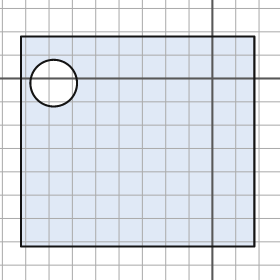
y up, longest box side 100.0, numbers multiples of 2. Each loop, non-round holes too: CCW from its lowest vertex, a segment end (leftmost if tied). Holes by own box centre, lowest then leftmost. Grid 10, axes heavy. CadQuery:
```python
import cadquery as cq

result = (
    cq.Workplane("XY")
    .moveTo(-82.0, -72.0)
    .lineTo(18.0, -72.0)
    .lineTo(18.0, 18.0)
    .lineTo(-82.0, 18.0)
    .close()
    .moveTo(-68.0, -2.0)
    .circle(10.0)
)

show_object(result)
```